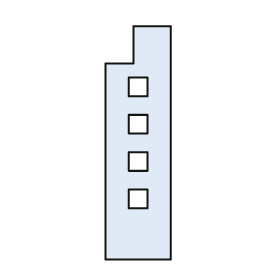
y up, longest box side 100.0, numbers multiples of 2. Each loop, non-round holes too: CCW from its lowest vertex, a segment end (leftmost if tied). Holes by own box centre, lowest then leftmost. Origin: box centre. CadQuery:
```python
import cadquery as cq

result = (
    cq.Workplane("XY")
    .moveTo(-14.0, -50.0)
    .lineTo(14.0, -50.0)
    .lineTo(14.0, 50.0)
    .lineTo(-2.0, 50.0)
    .lineTo(-2.0, 34.0)
    .lineTo(-14.0, 34.0)
    .close()
    .moveTo(-4.0, -28.0)
    .lineTo(4.0, -28.0)
    .lineTo(4.0, -20.0)
    .lineTo(-4.0, -20.0)
    .close()
    .moveTo(-4.0, -12.0)
    .lineTo(4.0, -12.0)
    .lineTo(4.0, -4.0)
    .lineTo(-4.0, -4.0)
    .close()
    .moveTo(-4.0, 4.0)
    .lineTo(4.0, 4.0)
    .lineTo(4.0, 12.0)
    .lineTo(-4.0, 12.0)
    .close()
    .moveTo(-4.0, 20.0)
    .lineTo(4.0, 20.0)
    .lineTo(4.0, 28.0)
    .lineTo(-4.0, 28.0)
    .close()
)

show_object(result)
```